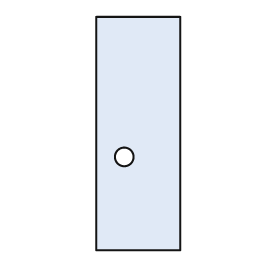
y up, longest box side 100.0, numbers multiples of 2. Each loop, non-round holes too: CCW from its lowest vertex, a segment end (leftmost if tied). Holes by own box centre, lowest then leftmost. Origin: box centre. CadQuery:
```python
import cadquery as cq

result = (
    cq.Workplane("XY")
    .moveTo(-18.0, -50.0)
    .lineTo(18.0, -50.0)
    .lineTo(18.0, 50.0)
    .lineTo(-18.0, 50.0)
    .close()
    .moveTo(-6.0, -10.0)
    .circle(4.0)
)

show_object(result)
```